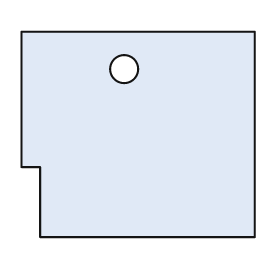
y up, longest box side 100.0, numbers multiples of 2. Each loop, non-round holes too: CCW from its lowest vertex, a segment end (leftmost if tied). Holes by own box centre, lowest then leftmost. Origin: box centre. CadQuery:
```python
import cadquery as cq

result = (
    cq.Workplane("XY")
    .moveTo(-42.0, -44.0)
    .lineTo(50.0, -44.0)
    .lineTo(50.0, 44.0)
    .lineTo(-50.0, 44.0)
    .lineTo(-50.0, -14.0)
    .lineTo(-42.0, -14.0)
    .close()
    .moveTo(-6.0, 28.0)
    .circle(6.0)
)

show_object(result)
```